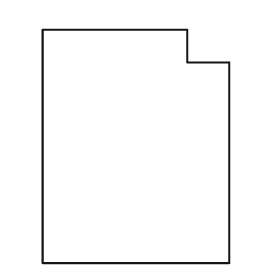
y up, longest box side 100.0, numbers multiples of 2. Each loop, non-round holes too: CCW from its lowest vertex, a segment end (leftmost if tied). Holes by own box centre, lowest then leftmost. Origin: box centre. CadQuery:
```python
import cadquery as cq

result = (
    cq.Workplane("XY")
    .moveTo(-40.0, -50.0)
    .lineTo(40.0, -50.0)
    .lineTo(40.0, 36.0)
    .lineTo(22.0, 36.0)
    .lineTo(22.0, 50.0)
    .lineTo(-40.0, 50.0)
    .close()
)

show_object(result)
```